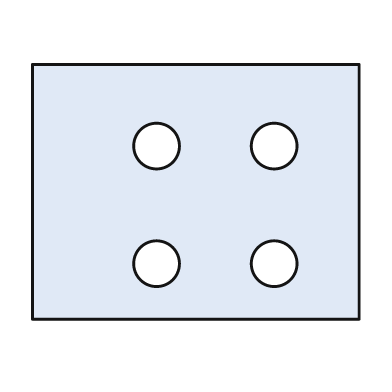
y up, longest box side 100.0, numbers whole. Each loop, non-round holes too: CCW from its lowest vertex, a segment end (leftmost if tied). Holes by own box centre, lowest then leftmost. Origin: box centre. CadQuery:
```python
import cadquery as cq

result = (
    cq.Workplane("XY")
    .moveTo(-50.0, -39.0)
    .lineTo(50.0, -39.0)
    .lineTo(50.0, 39.0)
    .lineTo(-50.0, 39.0)
    .close()
    .moveTo(-12.0, -22.0)
    .circle(7.0)
    .moveTo(24.0, -22.0)
    .circle(7.0)
    .moveTo(-12.0, 14.0)
    .circle(7.0)
    .moveTo(24.0, 14.0)
    .circle(7.0)
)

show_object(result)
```